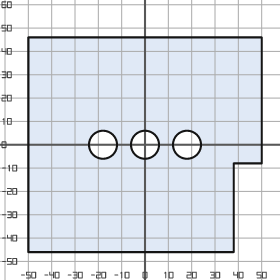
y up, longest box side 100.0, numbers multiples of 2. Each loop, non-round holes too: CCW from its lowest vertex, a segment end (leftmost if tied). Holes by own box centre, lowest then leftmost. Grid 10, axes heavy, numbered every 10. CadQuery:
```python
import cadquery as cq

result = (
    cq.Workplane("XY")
    .moveTo(-50.0, -46.0)
    .lineTo(38.0, -46.0)
    .lineTo(38.0, -8.0)
    .lineTo(50.0, -8.0)
    .lineTo(50.0, 46.0)
    .lineTo(-50.0, 46.0)
    .close()
    .moveTo(-18.0, 0.0)
    .circle(6.0)
    .moveTo(0.0, 0.0)
    .circle(6.0)
    .moveTo(18.0, 0.0)
    .circle(6.0)
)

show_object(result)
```